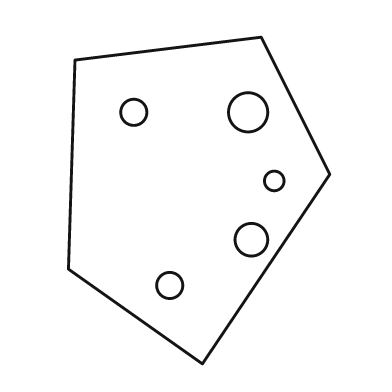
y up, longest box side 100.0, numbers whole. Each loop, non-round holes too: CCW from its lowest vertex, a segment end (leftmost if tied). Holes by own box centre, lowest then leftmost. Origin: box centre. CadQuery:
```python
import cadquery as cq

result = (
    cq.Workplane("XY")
    .moveTo(1.0, -50.0)
    .lineTo(40.0, 8.0)
    .lineTo(19.0, 50.0)
    .lineTo(-38.0, 43.0)
    .lineTo(-40.0, -21.0)
    .close()
    .moveTo(-9.0, -26.0)
    .circle(4.0)
    .moveTo(16.0, -12.0)
    .circle(5.0)
    .moveTo(23.0, 6.0)
    .circle(3.0)
    .moveTo(-20.0, 27.0)
    .circle(4.0)
    .moveTo(15.0, 27.0)
    .circle(6.0)
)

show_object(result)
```